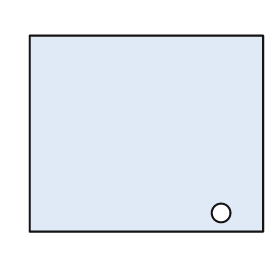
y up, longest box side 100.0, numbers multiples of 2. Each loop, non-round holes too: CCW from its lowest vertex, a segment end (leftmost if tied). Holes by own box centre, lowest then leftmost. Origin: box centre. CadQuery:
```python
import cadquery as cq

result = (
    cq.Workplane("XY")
    .moveTo(-50.0, -42.0)
    .lineTo(50.0, -42.0)
    .lineTo(50.0, 42.0)
    .lineTo(-50.0, 42.0)
    .close()
    .moveTo(32.0, -34.0)
    .circle(4.0)
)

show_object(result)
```